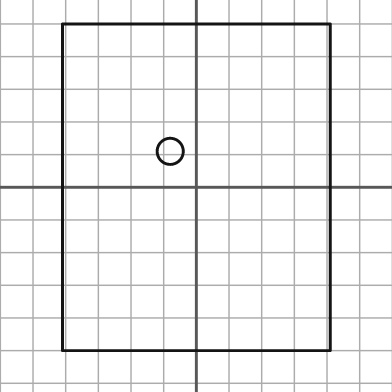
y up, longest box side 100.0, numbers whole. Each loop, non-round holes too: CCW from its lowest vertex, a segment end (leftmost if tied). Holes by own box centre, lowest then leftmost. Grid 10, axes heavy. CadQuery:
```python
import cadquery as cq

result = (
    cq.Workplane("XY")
    .moveTo(-41.0, -50.0)
    .lineTo(41.0, -50.0)
    .lineTo(41.0, 50.0)
    .lineTo(-41.0, 50.0)
    .close()
    .moveTo(-8.0, 11.0)
    .circle(4.0)
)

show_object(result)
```